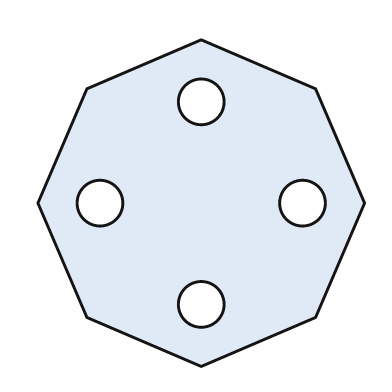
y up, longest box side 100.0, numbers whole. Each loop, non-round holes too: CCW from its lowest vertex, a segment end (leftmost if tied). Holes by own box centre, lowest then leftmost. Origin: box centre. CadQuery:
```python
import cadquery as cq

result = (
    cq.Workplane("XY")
    .moveTo(0.0, -50.0)
    .lineTo(35.0, -35.0)
    .lineTo(50.0, 0.0)
    .lineTo(35.0, 35.0)
    .lineTo(0.0, 50.0)
    .lineTo(-35.0, 35.0)
    .lineTo(-50.0, 0.0)
    .lineTo(-35.0, -35.0)
    .close()
    .moveTo(0.0, -31.0)
    .circle(7.0)
    .moveTo(-31.0, 0.0)
    .circle(7.0)
    .moveTo(31.0, 0.0)
    .circle(7.0)
    .moveTo(0.0, 31.0)
    .circle(7.0)
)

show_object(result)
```